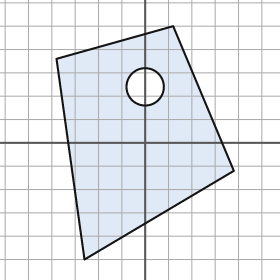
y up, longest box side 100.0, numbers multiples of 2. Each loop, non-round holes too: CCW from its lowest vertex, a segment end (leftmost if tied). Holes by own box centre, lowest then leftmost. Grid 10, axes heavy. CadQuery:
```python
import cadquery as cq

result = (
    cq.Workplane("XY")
    .moveTo(-26.0, -50.0)
    .lineTo(38.0, -12.0)
    .lineTo(12.0, 50.0)
    .lineTo(-38.0, 36.0)
    .close()
    .moveTo(0.0, 24.0)
    .circle(8.0)
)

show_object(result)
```